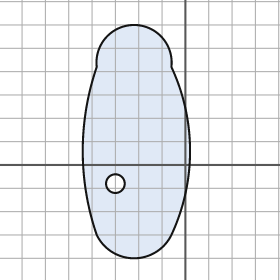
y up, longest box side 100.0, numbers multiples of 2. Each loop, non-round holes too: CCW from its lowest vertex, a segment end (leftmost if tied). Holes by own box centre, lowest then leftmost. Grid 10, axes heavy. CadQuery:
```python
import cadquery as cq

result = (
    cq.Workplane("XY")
    .moveTo(-38.0, -30.0)
    .threePointArc((-22.0, -40.0), (-6.0, -30.0))
    .threePointArc((2.0, 6.0), (-6.0, 42.0))
    .threePointArc((-22.0, 60.0), (-38.0, 42.0))
    .threePointArc((-44.0, 6.0), (-38.0, -30.0))
    .close()
    .moveTo(-30.0, -8.0)
    .circle(4.0)
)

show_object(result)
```